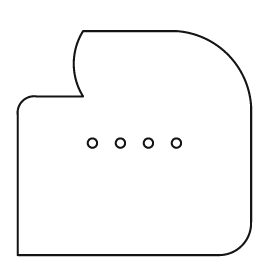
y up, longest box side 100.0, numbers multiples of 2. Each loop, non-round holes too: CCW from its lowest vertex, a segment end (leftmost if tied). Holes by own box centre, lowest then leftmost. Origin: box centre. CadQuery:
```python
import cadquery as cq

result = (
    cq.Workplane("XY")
    .moveTo(-50.0, -48.0)
    .lineTo(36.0, -48.0)
    .threePointArc((46.0, -44.0), (50.0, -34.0))
    .lineTo(50.0, 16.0)
    .threePointArc((40.0, 38.0), (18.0, 48.0))
    .lineTo(-22.0, 48.0)
    .threePointArc((-26.0, 34.0), (-22.0, 20.0))
    .lineTo(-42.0, 20.0)
    .threePointArc((-48.0, 18.0), (-50.0, 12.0))
    .close()
    .moveTo(-18.0, 0.0)
    .circle(2.0)
    .moveTo(-6.0, 0.0)
    .circle(2.0)
    .moveTo(6.0, 0.0)
    .circle(2.0)
    .moveTo(18.0, 0.0)
    .circle(2.0)
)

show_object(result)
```